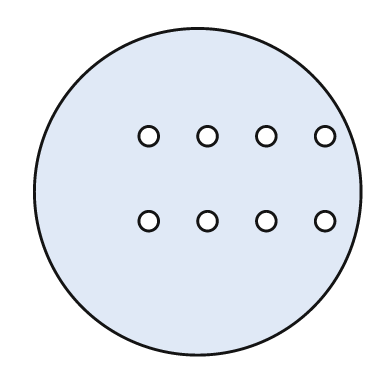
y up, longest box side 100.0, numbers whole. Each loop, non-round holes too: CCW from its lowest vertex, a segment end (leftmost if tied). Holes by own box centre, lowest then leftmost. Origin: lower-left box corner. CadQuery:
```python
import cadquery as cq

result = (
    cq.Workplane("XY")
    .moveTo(50.0, 50.0)
    .circle(50.0)
    .moveTo(35.0, 41.0)
    .circle(3.0)
    .moveTo(53.0, 41.0)
    .circle(3.0)
    .moveTo(71.0, 41.0)
    .circle(3.0)
    .moveTo(89.0, 41.0)
    .circle(3.0)
    .moveTo(35.0, 67.0)
    .circle(3.0)
    .moveTo(53.0, 67.0)
    .circle(3.0)
    .moveTo(71.0, 67.0)
    .circle(3.0)
    .moveTo(89.0, 67.0)
    .circle(3.0)
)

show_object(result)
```